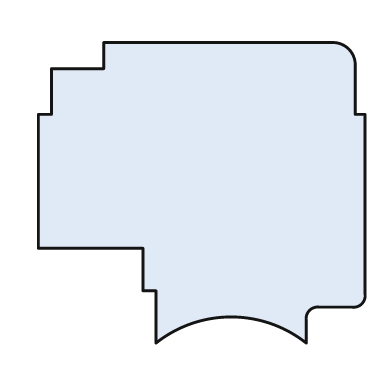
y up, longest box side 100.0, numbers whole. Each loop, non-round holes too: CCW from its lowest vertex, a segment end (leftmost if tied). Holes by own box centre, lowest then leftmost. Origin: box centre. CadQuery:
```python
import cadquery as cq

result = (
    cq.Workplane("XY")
    .moveTo(-14.0, -46.0)
    .threePointArc((9.0, -38.0), (32.0, -46.0))
    .lineTo(32.0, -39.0)
    .threePointArc((33.0, -36.0), (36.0, -35.0))
    .lineTo(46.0, -35.0)
    .threePointArc((49.0, -34.0), (50.0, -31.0))
    .lineTo(50.0, 24.0)
    .lineTo(47.0, 24.0)
    .lineTo(47.0, 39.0)
    .threePointArc((45.0, 44.0), (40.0, 46.0))
    .lineTo(-30.0, 46.0)
    .lineTo(-30.0, 38.0)
    .lineTo(-46.0, 38.0)
    .lineTo(-46.0, 24.0)
    .lineTo(-50.0, 24.0)
    .lineTo(-50.0, -17.0)
    .lineTo(-18.0, -17.0)
    .lineTo(-18.0, -30.0)
    .lineTo(-14.0, -30.0)
    .close()
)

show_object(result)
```